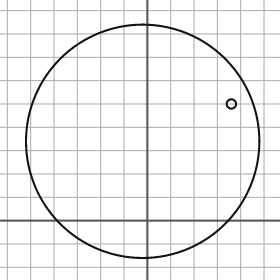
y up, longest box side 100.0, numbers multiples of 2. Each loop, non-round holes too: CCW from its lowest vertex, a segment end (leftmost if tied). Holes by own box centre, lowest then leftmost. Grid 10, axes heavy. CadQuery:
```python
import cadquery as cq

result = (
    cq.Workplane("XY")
    .moveTo(-2.0, 34.0)
    .circle(50.0)
    .moveTo(36.0, 50.0)
    .circle(2.0)
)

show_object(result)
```